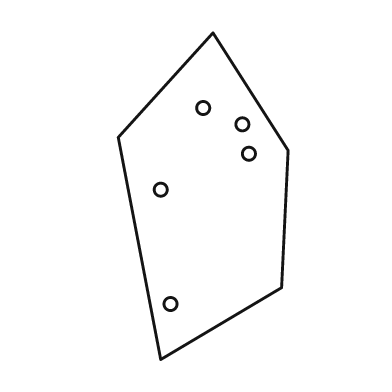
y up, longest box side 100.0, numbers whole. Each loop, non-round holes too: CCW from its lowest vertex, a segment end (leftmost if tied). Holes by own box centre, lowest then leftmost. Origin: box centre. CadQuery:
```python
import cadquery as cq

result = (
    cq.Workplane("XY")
    .moveTo(-13.0, -50.0)
    .lineTo(24.0, -28.0)
    .lineTo(26.0, 14.0)
    .lineTo(3.0, 50.0)
    .lineTo(-26.0, 18.0)
    .close()
    .moveTo(-10.0, -33.0)
    .circle(2.0)
    .moveTo(-13.0, 2.0)
    .circle(2.0)
    .moveTo(14.0, 13.0)
    .circle(2.0)
    .moveTo(12.0, 22.0)
    .circle(2.0)
    .moveTo(0.0, 27.0)
    .circle(2.0)
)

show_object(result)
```